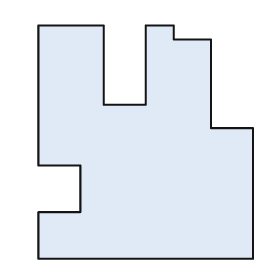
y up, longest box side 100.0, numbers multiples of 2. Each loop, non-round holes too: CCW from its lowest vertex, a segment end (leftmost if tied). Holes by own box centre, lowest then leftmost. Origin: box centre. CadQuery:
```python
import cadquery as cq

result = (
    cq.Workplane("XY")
    .moveTo(-46.0, -50.0)
    .lineTo(46.0, -50.0)
    .lineTo(46.0, 6.0)
    .lineTo(28.0, 6.0)
    .lineTo(28.0, 44.0)
    .lineTo(12.0, 44.0)
    .lineTo(12.0, 50.0)
    .lineTo(0.0, 50.0)
    .lineTo(0.0, 16.0)
    .lineTo(-18.0, 16.0)
    .lineTo(-18.0, 50.0)
    .lineTo(-46.0, 50.0)
    .lineTo(-46.0, -10.0)
    .lineTo(-28.0, -10.0)
    .lineTo(-28.0, -30.0)
    .lineTo(-46.0, -30.0)
    .close()
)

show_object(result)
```